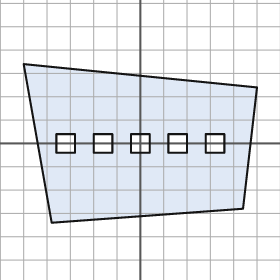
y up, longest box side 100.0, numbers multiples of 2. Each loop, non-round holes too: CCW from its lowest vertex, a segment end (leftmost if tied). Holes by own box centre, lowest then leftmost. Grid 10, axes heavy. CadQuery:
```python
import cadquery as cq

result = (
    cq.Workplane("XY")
    .moveTo(-38.0, -34.0)
    .lineTo(44.0, -28.0)
    .lineTo(50.0, 24.0)
    .lineTo(-50.0, 34.0)
    .close()
    .moveTo(-36.0, -4.0)
    .lineTo(-28.0, -4.0)
    .lineTo(-28.0, 4.0)
    .lineTo(-36.0, 4.0)
    .close()
    .moveTo(-20.0, -4.0)
    .lineTo(-12.0, -4.0)
    .lineTo(-12.0, 4.0)
    .lineTo(-20.0, 4.0)
    .close()
    .moveTo(-4.0, -4.0)
    .lineTo(4.0, -4.0)
    .lineTo(4.0, 4.0)
    .lineTo(-4.0, 4.0)
    .close()
    .moveTo(12.0, -4.0)
    .lineTo(20.0, -4.0)
    .lineTo(20.0, 4.0)
    .lineTo(12.0, 4.0)
    .close()
    .moveTo(28.0, -4.0)
    .lineTo(36.0, -4.0)
    .lineTo(36.0, 4.0)
    .lineTo(28.0, 4.0)
    .close()
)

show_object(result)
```